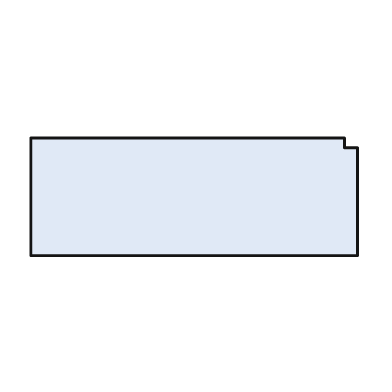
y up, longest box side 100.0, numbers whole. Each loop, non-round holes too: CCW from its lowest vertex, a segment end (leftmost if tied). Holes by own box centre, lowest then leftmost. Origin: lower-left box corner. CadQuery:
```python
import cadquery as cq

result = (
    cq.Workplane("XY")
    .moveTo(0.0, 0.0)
    .lineTo(100.0, 0.0)
    .lineTo(100.0, 33.0)
    .lineTo(96.0, 33.0)
    .lineTo(96.0, 36.0)
    .lineTo(0.0, 36.0)
    .close()
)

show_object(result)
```